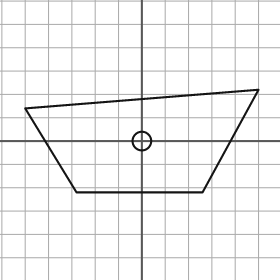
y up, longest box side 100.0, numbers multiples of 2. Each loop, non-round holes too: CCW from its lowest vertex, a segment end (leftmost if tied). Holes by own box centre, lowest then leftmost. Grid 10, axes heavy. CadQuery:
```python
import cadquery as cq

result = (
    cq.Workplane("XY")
    .moveTo(-28.0, -22.0)
    .lineTo(26.0, -22.0)
    .lineTo(50.0, 22.0)
    .lineTo(-50.0, 14.0)
    .close()
    .moveTo(0.0, 0.0)
    .circle(4.0)
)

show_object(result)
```